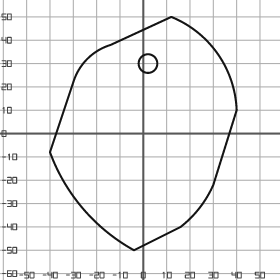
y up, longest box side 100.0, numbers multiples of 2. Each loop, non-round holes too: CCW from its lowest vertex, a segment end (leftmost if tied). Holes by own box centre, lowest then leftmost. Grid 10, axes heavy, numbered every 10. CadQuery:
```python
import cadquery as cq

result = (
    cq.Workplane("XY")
    .moveTo(-4.0, -50.0)
    .lineTo(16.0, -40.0)
    .threePointArc((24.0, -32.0), (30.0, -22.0))
    .lineTo(40.0, 10.0)
    .threePointArc((32.0, 34.0), (12.0, 50.0))
    .lineTo(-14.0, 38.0)
    .threePointArc((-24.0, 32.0), (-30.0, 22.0))
    .lineTo(-40.0, -8.0)
    .threePointArc((-26.0, -32.0), (-4.0, -50.0))
    .close()
    .moveTo(2.0, 30.0)
    .circle(4.0)
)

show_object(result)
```